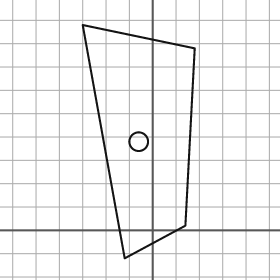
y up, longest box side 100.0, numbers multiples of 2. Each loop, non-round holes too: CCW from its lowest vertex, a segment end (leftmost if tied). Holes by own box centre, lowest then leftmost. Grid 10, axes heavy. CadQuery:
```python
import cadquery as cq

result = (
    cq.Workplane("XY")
    .moveTo(-12.0, -12.0)
    .lineTo(14.0, 2.0)
    .lineTo(18.0, 78.0)
    .lineTo(-30.0, 88.0)
    .close()
    .moveTo(-6.0, 38.0)
    .circle(4.0)
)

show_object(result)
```